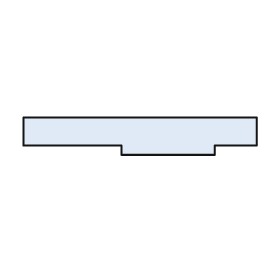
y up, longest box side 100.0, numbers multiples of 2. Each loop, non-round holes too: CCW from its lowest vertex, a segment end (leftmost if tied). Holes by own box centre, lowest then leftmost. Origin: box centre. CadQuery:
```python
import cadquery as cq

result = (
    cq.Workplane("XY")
    .moveTo(-8.0, -8.0)
    .lineTo(32.0, -8.0)
    .lineTo(32.0, -4.0)
    .lineTo(50.0, -4.0)
    .lineTo(50.0, 8.0)
    .lineTo(-50.0, 8.0)
    .lineTo(-50.0, -4.0)
    .lineTo(-8.0, -4.0)
    .close()
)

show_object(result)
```